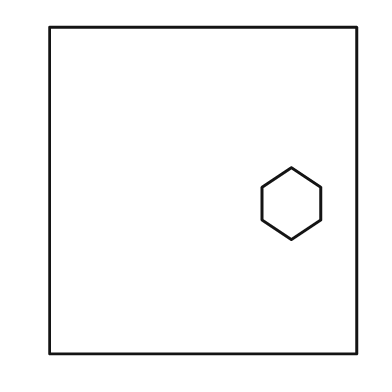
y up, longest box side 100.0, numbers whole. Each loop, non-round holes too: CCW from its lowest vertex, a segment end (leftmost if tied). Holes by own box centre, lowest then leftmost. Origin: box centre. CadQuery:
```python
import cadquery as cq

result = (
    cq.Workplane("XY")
    .moveTo(-47.0, -50.0)
    .lineTo(47.0, -50.0)
    .lineTo(47.0, 50.0)
    .lineTo(-47.0, 50.0)
    .close()
    .moveTo(27.0, -15.0)
    .lineTo(36.0, -9.0)
    .lineTo(36.0, 1.0)
    .lineTo(27.0, 7.0)
    .lineTo(18.0, 1.0)
    .lineTo(18.0, -9.0)
    .close()
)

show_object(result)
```